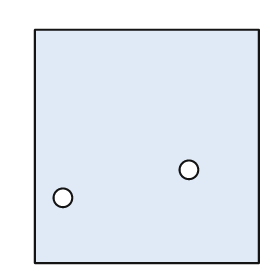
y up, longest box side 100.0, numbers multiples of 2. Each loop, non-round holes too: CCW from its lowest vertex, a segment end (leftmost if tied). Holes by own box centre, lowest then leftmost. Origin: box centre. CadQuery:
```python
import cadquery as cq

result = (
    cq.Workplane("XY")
    .moveTo(-48.0, -50.0)
    .lineTo(48.0, -50.0)
    .lineTo(48.0, 50.0)
    .lineTo(-48.0, 50.0)
    .close()
    .moveTo(-36.0, -22.0)
    .circle(4.0)
    .moveTo(18.0, -10.0)
    .circle(4.0)
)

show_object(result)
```